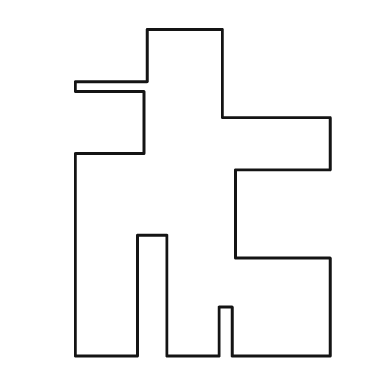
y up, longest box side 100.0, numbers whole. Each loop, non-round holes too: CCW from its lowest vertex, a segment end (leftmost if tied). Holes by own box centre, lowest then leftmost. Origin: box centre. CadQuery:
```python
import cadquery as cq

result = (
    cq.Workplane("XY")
    .moveTo(-39.0, -50.0)
    .lineTo(-20.0, -50.0)
    .lineTo(-20.0, -13.0)
    .lineTo(-11.0, -13.0)
    .lineTo(-11.0, -50.0)
    .lineTo(5.0, -50.0)
    .lineTo(5.0, -35.0)
    .lineTo(9.0, -35.0)
    .lineTo(9.0, -50.0)
    .lineTo(39.0, -50.0)
    .lineTo(39.0, -20.0)
    .lineTo(10.0, -20.0)
    .lineTo(10.0, 7.0)
    .lineTo(39.0, 7.0)
    .lineTo(39.0, 23.0)
    .lineTo(6.0, 23.0)
    .lineTo(6.0, 50.0)
    .lineTo(-17.0, 50.0)
    .lineTo(-17.0, 34.0)
    .lineTo(-39.0, 34.0)
    .lineTo(-39.0, 31.0)
    .lineTo(-18.0, 31.0)
    .lineTo(-18.0, 12.0)
    .lineTo(-39.0, 12.0)
    .close()
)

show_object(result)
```